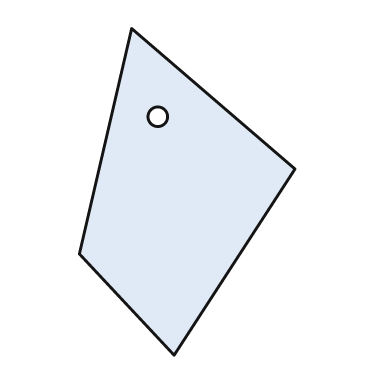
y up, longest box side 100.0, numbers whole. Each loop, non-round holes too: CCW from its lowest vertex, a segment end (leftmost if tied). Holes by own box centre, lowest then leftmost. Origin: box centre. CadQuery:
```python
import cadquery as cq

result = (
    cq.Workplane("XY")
    .moveTo(-4.0, -50.0)
    .lineTo(33.0, 7.0)
    .lineTo(-17.0, 50.0)
    .lineTo(-33.0, -19.0)
    .close()
    .moveTo(-9.0, 23.0)
    .circle(3.0)
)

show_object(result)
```